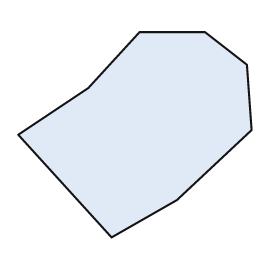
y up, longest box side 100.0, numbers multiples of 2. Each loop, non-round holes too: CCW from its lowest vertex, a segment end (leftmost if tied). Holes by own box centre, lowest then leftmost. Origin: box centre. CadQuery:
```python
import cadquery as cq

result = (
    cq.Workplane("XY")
    .moveTo(-10.0, -44.0)
    .lineTo(18.0, -28.0)
    .lineTo(50.0, 2.0)
    .lineTo(48.0, 30.0)
    .lineTo(30.0, 44.0)
    .lineTo(2.0, 44.0)
    .lineTo(-20.0, 20.0)
    .lineTo(-50.0, 0.0)
    .close()
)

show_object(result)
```